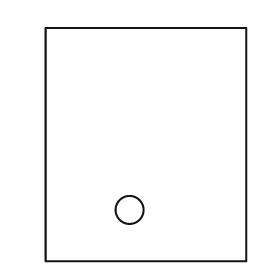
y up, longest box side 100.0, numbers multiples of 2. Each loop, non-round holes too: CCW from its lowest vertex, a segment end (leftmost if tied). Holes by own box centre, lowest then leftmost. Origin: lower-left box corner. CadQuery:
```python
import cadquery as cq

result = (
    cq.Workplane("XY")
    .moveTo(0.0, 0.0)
    .lineTo(86.0, 0.0)
    .lineTo(86.0, 100.0)
    .lineTo(0.0, 100.0)
    .close()
    .moveTo(36.0, 22.0)
    .circle(6.0)
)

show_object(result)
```